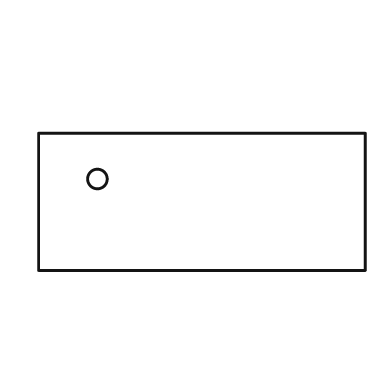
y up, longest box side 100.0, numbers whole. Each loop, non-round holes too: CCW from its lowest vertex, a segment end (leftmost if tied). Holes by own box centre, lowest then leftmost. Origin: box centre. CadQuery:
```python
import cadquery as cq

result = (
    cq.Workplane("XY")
    .moveTo(-50.0, -21.0)
    .lineTo(50.0, -21.0)
    .lineTo(50.0, 21.0)
    .lineTo(-50.0, 21.0)
    .close()
    .moveTo(-32.0, 7.0)
    .circle(3.0)
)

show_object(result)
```